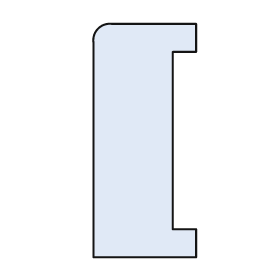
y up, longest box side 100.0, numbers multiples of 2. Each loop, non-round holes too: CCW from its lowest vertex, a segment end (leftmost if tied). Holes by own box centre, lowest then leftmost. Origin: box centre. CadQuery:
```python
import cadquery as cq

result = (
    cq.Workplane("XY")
    .moveTo(-22.0, -50.0)
    .lineTo(22.0, -50.0)
    .lineTo(22.0, -38.0)
    .lineTo(12.0, -38.0)
    .lineTo(12.0, 38.0)
    .lineTo(22.0, 38.0)
    .lineTo(22.0, 50.0)
    .lineTo(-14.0, 50.0)
    .threePointArc((-20.0, 48.0), (-22.0, 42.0))
    .close()
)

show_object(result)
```